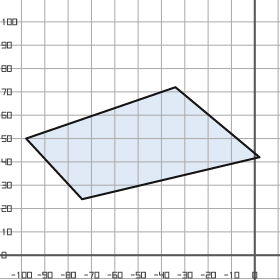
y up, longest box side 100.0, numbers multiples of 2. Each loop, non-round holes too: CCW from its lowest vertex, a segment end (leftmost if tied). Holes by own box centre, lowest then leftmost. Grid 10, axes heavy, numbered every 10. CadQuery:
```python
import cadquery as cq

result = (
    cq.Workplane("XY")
    .moveTo(-74.0, 24.0)
    .lineTo(2.0, 42.0)
    .lineTo(-34.0, 72.0)
    .lineTo(-98.0, 50.0)
    .close()
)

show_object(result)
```